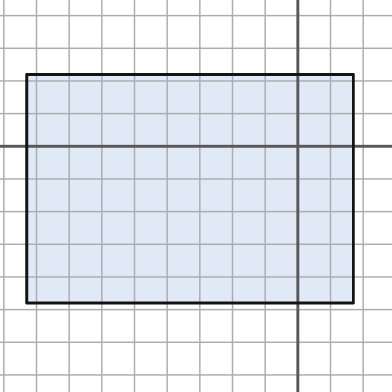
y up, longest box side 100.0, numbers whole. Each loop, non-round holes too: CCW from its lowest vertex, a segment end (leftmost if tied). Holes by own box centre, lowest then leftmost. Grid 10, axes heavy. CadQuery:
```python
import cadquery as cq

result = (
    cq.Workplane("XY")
    .moveTo(-83.0, -48.0)
    .lineTo(17.0, -48.0)
    .lineTo(17.0, 22.0)
    .lineTo(-83.0, 22.0)
    .close()
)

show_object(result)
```